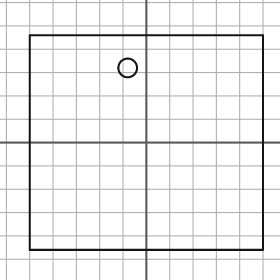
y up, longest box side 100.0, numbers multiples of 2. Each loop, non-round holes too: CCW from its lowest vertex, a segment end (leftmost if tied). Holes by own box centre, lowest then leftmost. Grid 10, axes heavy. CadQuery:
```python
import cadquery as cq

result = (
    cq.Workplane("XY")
    .moveTo(-50.0, -46.0)
    .lineTo(50.0, -46.0)
    .lineTo(50.0, 46.0)
    .lineTo(-50.0, 46.0)
    .close()
    .moveTo(-8.0, 32.0)
    .circle(4.0)
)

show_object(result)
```